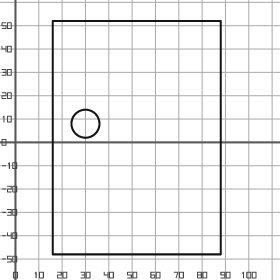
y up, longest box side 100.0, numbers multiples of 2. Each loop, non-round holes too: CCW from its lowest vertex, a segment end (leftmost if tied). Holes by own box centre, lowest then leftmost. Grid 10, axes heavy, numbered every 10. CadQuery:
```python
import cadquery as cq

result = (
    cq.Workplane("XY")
    .moveTo(16.0, -48.0)
    .lineTo(88.0, -48.0)
    .lineTo(88.0, 52.0)
    .lineTo(16.0, 52.0)
    .close()
    .moveTo(30.0, 8.0)
    .circle(6.0)
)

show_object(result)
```